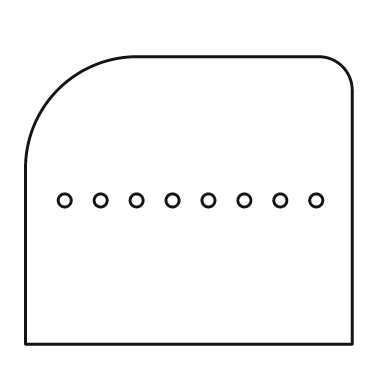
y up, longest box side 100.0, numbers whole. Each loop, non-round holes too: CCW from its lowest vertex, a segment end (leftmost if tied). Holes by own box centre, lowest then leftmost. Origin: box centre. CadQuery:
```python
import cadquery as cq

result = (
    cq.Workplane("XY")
    .moveTo(-50.0, -44.0)
    .lineTo(50.0, -44.0)
    .lineTo(50.0, 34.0)
    .threePointArc((47.0, 41.0), (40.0, 44.0))
    .lineTo(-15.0, 44.0)
    .threePointArc((-40.0, 34.0), (-50.0, 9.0))
    .close()
    .moveTo(-38.0, 0.0)
    .circle(2.0)
    .moveTo(-27.0, 0.0)
    .circle(2.0)
    .moveTo(-16.0, 0.0)
    .circle(2.0)
    .moveTo(-5.0, 0.0)
    .circle(2.0)
    .moveTo(6.0, 0.0)
    .circle(2.0)
    .moveTo(17.0, 0.0)
    .circle(2.0)
    .moveTo(28.0, 0.0)
    .circle(2.0)
    .moveTo(39.0, 0.0)
    .circle(2.0)
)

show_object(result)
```